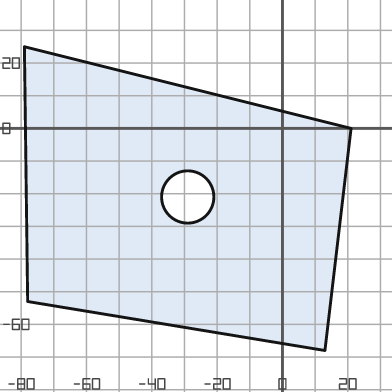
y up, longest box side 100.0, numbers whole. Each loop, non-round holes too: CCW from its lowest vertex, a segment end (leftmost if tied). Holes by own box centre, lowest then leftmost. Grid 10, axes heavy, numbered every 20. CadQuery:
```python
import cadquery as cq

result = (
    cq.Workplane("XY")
    .moveTo(13.0, -68.0)
    .lineTo(21.0, 0.0)
    .lineTo(-79.0, 25.0)
    .lineTo(-78.0, -53.0)
    .close()
    .moveTo(-29.0, -21.0)
    .circle(8.0)
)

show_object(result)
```